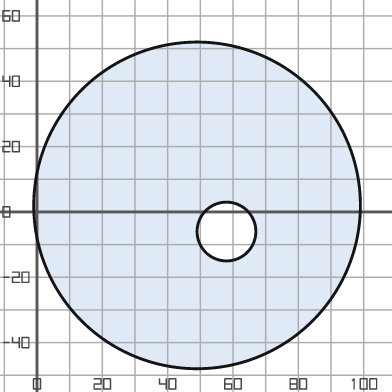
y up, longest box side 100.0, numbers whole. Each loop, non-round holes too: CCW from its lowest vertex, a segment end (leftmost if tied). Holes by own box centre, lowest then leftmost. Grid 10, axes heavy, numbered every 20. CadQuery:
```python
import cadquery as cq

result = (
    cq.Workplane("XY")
    .moveTo(49.0, 2.0)
    .circle(50.0)
    .moveTo(58.0, -6.0)
    .circle(9.0)
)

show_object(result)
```